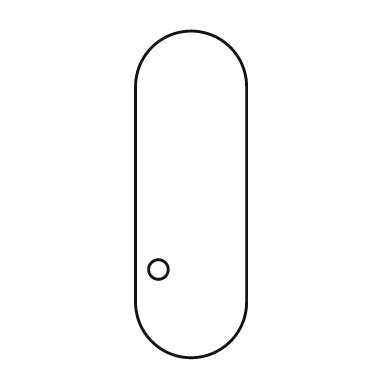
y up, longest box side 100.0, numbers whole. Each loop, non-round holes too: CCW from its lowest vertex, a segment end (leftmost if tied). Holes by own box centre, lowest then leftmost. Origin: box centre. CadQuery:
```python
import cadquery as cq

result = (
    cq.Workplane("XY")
    .moveTo(-17.0, -33.0)
    .threePointArc((0.0, -50.0), (17.0, -33.0))
    .lineTo(17.0, 33.0)
    .threePointArc((0.0, 50.0), (-17.0, 33.0))
    .close()
    .moveTo(-10.0, -23.0)
    .circle(3.0)
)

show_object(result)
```